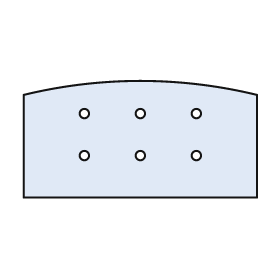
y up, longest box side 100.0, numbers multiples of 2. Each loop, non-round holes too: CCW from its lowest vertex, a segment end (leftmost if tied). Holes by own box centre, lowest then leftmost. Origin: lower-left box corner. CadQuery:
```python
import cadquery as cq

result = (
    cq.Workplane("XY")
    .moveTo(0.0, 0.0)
    .lineTo(100.0, 0.0)
    .lineTo(100.0, 44.0)
    .threePointArc((50.0, 50.0), (0.0, 44.0))
    .close()
    .moveTo(26.0, 18.0)
    .circle(2.0)
    .moveTo(50.0, 18.0)
    .circle(2.0)
    .moveTo(74.0, 18.0)
    .circle(2.0)
    .moveTo(26.0, 36.0)
    .circle(2.0)
    .moveTo(50.0, 36.0)
    .circle(2.0)
    .moveTo(74.0, 36.0)
    .circle(2.0)
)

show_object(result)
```